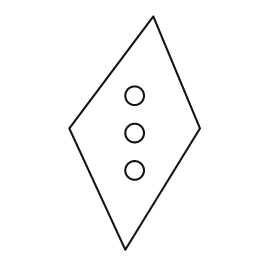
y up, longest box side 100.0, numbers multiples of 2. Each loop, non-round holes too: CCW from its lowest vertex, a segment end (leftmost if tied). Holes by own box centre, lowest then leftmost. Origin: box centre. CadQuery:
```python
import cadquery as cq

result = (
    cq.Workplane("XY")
    .moveTo(-4.0, -50.0)
    .lineTo(28.0, 2.0)
    .lineTo(8.0, 50.0)
    .lineTo(-28.0, 2.0)
    .close()
    .moveTo(0.0, -16.0)
    .circle(4.0)
    .moveTo(0.0, 0.0)
    .circle(4.0)
    .moveTo(0.0, 16.0)
    .circle(4.0)
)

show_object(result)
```